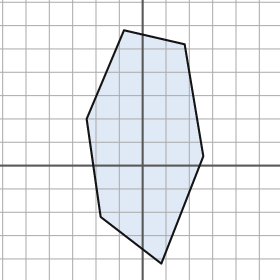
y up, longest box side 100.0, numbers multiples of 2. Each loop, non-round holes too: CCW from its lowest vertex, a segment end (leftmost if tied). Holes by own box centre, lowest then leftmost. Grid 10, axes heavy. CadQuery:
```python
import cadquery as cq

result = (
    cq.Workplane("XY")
    .moveTo(8.0, -42.0)
    .lineTo(26.0, 4.0)
    .lineTo(18.0, 52.0)
    .lineTo(-8.0, 58.0)
    .lineTo(-24.0, 20.0)
    .lineTo(-18.0, -22.0)
    .close()
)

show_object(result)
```